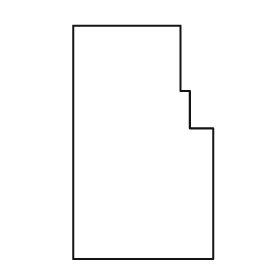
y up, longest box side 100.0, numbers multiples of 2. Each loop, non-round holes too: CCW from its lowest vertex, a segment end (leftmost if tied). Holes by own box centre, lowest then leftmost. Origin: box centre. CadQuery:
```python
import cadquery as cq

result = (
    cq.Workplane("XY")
    .moveTo(-30.0, -50.0)
    .lineTo(30.0, -50.0)
    .lineTo(30.0, 6.0)
    .lineTo(20.0, 6.0)
    .lineTo(20.0, 22.0)
    .lineTo(16.0, 22.0)
    .lineTo(16.0, 50.0)
    .lineTo(-30.0, 50.0)
    .close()
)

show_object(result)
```